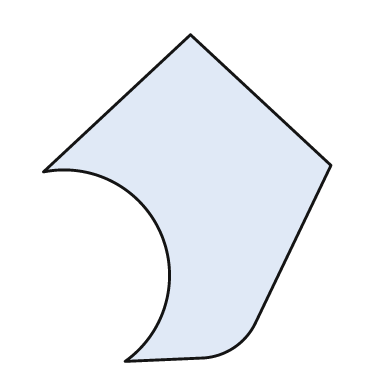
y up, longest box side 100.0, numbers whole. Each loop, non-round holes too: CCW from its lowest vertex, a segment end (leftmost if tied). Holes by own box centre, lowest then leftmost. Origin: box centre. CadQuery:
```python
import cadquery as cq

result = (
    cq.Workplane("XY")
    .moveTo(-19.0, -50.0)
    .lineTo(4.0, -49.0)
    .threePointArc((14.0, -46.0), (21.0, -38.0))
    .lineTo(44.0, 10.0)
    .lineTo(1.0, 50.0)
    .lineTo(-44.0, 8.0)
    .threePointArc((-8.0, -11.0), (-19.0, -50.0))
    .close()
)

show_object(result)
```